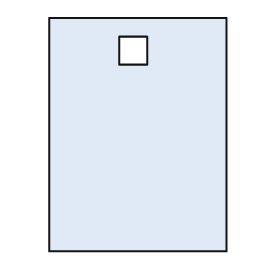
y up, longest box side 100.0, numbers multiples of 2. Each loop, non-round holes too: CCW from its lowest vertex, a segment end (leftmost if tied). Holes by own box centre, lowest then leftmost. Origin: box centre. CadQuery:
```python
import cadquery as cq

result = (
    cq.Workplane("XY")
    .moveTo(-38.0, -50.0)
    .lineTo(38.0, -50.0)
    .lineTo(38.0, 50.0)
    .lineTo(-38.0, 50.0)
    .close()
    .moveTo(-8.0, 30.0)
    .lineTo(4.0, 30.0)
    .lineTo(4.0, 42.0)
    .lineTo(-8.0, 42.0)
    .close()
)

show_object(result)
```